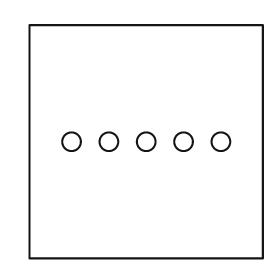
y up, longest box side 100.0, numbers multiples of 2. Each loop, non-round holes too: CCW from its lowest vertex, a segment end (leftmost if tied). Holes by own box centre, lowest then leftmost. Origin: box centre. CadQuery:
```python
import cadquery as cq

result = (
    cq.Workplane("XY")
    .moveTo(-50.0, -50.0)
    .lineTo(50.0, -50.0)
    .lineTo(50.0, 50.0)
    .lineTo(-50.0, 50.0)
    .close()
    .moveTo(-32.0, 0.0)
    .circle(4.0)
    .moveTo(-16.0, 0.0)
    .circle(4.0)
    .moveTo(0.0, 0.0)
    .circle(4.0)
    .moveTo(16.0, 0.0)
    .circle(4.0)
    .moveTo(32.0, 0.0)
    .circle(4.0)
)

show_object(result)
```